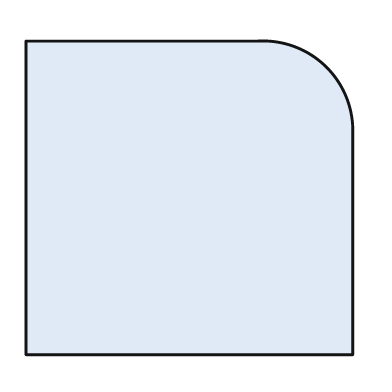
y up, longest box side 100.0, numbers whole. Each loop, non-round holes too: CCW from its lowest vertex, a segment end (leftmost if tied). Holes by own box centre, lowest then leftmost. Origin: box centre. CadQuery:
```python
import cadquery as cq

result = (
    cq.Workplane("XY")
    .moveTo(-50.0, -48.0)
    .lineTo(50.0, -48.0)
    .lineTo(50.0, 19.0)
    .threePointArc((42.0, 40.0), (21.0, 48.0))
    .lineTo(-50.0, 48.0)
    .close()
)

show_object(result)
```